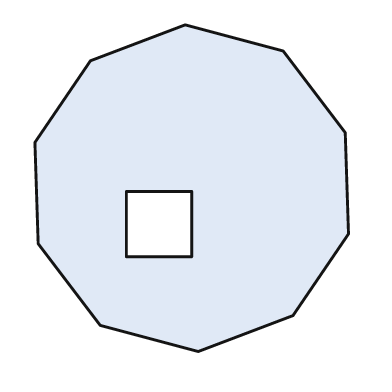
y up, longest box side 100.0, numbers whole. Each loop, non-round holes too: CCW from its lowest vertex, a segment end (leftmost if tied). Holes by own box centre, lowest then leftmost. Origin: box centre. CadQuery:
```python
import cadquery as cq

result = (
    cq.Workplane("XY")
    .moveTo(2.0, -50.0)
    .lineTo(31.0, -39.0)
    .lineTo(48.0, -14.0)
    .lineTo(47.0, 17.0)
    .lineTo(28.0, 42.0)
    .lineTo(-2.0, 50.0)
    .lineTo(-31.0, 39.0)
    .lineTo(-48.0, 14.0)
    .lineTo(-47.0, -17.0)
    .lineTo(-28.0, -42.0)
    .close()
    .moveTo(-20.0, -21.0)
    .lineTo(0.0, -21.0)
    .lineTo(0.0, -1.0)
    .lineTo(-20.0, -1.0)
    .close()
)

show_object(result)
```